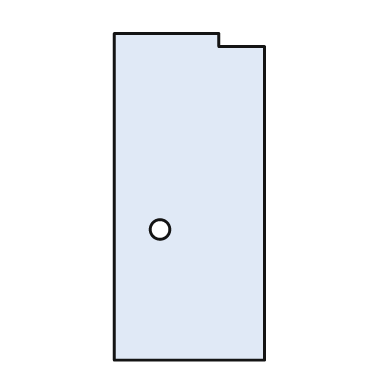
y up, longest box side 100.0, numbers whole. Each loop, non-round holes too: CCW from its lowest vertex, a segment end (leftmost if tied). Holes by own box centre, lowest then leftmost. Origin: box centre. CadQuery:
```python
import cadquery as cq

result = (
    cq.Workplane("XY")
    .moveTo(-23.0, -50.0)
    .lineTo(23.0, -50.0)
    .lineTo(23.0, 46.0)
    .lineTo(9.0, 46.0)
    .lineTo(9.0, 50.0)
    .lineTo(-23.0, 50.0)
    .close()
    .moveTo(-9.0, -10.0)
    .circle(3.0)
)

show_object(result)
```